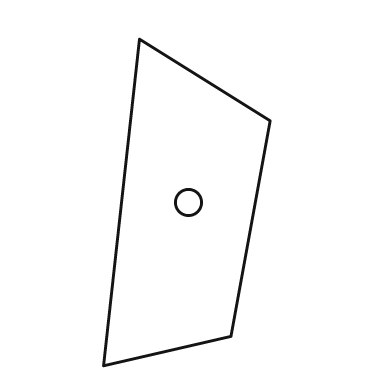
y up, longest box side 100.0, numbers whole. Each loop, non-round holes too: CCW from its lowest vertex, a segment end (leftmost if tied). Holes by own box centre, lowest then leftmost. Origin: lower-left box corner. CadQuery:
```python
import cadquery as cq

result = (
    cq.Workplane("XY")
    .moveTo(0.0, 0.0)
    .lineTo(39.0, 9.0)
    .lineTo(51.0, 75.0)
    .lineTo(11.0, 100.0)
    .close()
    .moveTo(26.0, 50.0)
    .circle(4.0)
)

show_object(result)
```